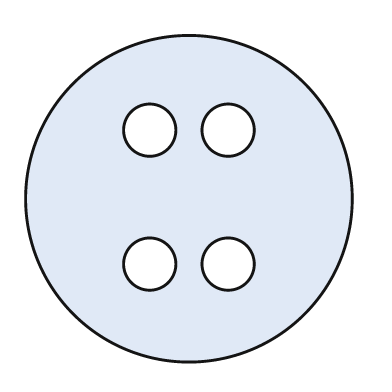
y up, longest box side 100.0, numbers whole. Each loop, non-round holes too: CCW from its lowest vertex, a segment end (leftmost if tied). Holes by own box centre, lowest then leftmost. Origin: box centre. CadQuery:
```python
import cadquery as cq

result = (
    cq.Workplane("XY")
    .moveTo(0.0, 0.0)
    .circle(50.0)
    .moveTo(-12.0, -20.0)
    .circle(8.0)
    .moveTo(12.0, -20.0)
    .circle(8.0)
    .moveTo(-12.0, 21.0)
    .circle(8.0)
    .moveTo(12.0, 21.0)
    .circle(8.0)
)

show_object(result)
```